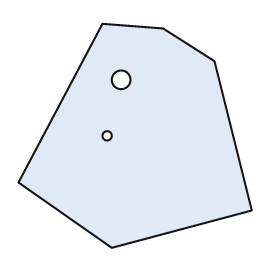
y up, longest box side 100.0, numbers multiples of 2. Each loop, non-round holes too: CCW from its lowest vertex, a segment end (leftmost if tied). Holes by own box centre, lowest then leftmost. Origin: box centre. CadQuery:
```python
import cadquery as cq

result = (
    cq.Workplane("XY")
    .moveTo(-10.0, -48.0)
    .lineTo(50.0, -32.0)
    .lineTo(34.0, 32.0)
    .lineTo(12.0, 46.0)
    .lineTo(-14.0, 48.0)
    .lineTo(-50.0, -20.0)
    .close()
    .moveTo(-12.0, 0.0)
    .circle(2.0)
    .moveTo(-6.0, 24.0)
    .circle(4.0)
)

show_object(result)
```